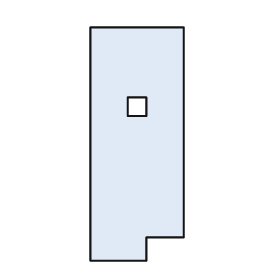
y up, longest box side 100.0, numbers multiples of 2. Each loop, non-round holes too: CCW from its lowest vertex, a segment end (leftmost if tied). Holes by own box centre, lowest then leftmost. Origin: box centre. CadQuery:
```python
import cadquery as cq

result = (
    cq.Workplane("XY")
    .moveTo(-20.0, -50.0)
    .lineTo(4.0, -50.0)
    .lineTo(4.0, -40.0)
    .lineTo(20.0, -40.0)
    .lineTo(20.0, 50.0)
    .lineTo(-20.0, 50.0)
    .close()
    .moveTo(-4.0, 12.0)
    .lineTo(4.0, 12.0)
    .lineTo(4.0, 20.0)
    .lineTo(-4.0, 20.0)
    .close()
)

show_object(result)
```